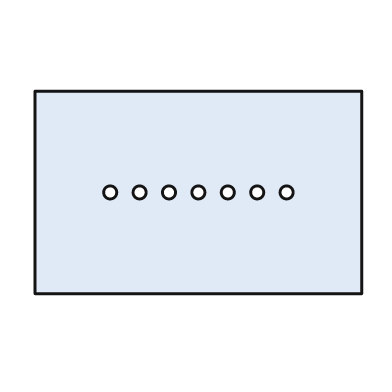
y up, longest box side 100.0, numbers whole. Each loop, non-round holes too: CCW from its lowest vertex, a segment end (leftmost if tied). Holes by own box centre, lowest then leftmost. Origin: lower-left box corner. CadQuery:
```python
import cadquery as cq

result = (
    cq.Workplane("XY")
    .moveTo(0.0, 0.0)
    .lineTo(100.0, 0.0)
    .lineTo(100.0, 62.0)
    .lineTo(0.0, 62.0)
    .close()
    .moveTo(23.0, 31.0)
    .circle(2.0)
    .moveTo(32.0, 31.0)
    .circle(2.0)
    .moveTo(41.0, 31.0)
    .circle(2.0)
    .moveTo(50.0, 31.0)
    .circle(2.0)
    .moveTo(59.0, 31.0)
    .circle(2.0)
    .moveTo(68.0, 31.0)
    .circle(2.0)
    .moveTo(77.0, 31.0)
    .circle(2.0)
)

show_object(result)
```